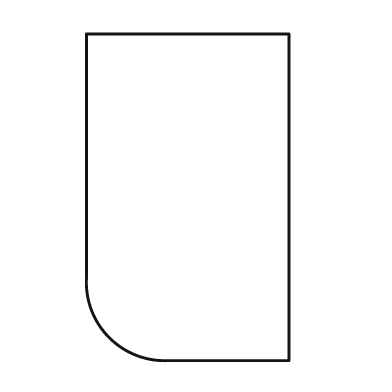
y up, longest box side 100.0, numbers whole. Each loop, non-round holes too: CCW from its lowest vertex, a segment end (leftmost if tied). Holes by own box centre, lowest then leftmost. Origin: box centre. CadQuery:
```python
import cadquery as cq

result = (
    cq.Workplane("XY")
    .moveTo(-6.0, -50.0)
    .lineTo(31.0, -50.0)
    .lineTo(31.0, 50.0)
    .lineTo(-31.0, 50.0)
    .lineTo(-31.0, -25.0)
    .threePointArc((-24.0, -43.0), (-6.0, -50.0))
    .close()
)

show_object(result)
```